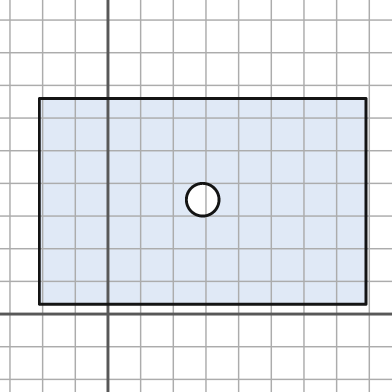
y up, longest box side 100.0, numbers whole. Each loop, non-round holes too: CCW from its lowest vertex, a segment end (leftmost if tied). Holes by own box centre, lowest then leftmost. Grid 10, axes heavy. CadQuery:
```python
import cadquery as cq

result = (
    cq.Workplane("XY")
    .moveTo(-21.0, 3.0)
    .lineTo(79.0, 3.0)
    .lineTo(79.0, 66.0)
    .lineTo(-21.0, 66.0)
    .close()
    .moveTo(29.0, 35.0)
    .circle(5.0)
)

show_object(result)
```